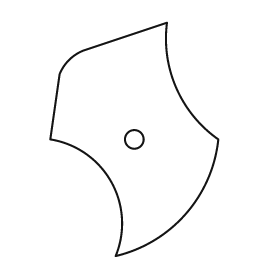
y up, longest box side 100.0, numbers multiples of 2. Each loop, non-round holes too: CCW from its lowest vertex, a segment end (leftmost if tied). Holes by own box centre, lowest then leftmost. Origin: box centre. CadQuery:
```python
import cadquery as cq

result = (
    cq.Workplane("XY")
    .moveTo(-8.0, -50.0)
    .threePointArc((22.0, -32.0), (36.0, 0.0))
    .threePointArc((18.0, 22.0), (14.0, 50.0))
    .lineTo(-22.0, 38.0)
    .threePointArc((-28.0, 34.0), (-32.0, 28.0))
    .lineTo(-36.0, 0.0)
    .threePointArc((-10.0, -18.0), (-8.0, -50.0))
    .close()
    .moveTo(0.0, 0.0)
    .circle(4.0)
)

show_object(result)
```